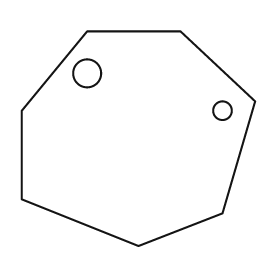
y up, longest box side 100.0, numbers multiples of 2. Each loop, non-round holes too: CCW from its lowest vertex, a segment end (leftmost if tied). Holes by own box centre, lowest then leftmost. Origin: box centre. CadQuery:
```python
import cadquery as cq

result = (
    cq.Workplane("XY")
    .moveTo(0.0, -46.0)
    .lineTo(36.0, -32.0)
    .lineTo(50.0, 16.0)
    .lineTo(18.0, 46.0)
    .lineTo(-22.0, 46.0)
    .lineTo(-50.0, 12.0)
    .lineTo(-50.0, -26.0)
    .close()
    .moveTo(36.0, 12.0)
    .circle(4.0)
    .moveTo(-22.0, 28.0)
    .circle(6.0)
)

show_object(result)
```